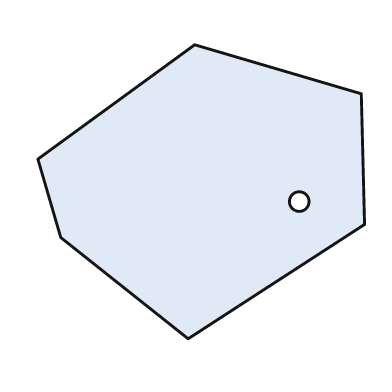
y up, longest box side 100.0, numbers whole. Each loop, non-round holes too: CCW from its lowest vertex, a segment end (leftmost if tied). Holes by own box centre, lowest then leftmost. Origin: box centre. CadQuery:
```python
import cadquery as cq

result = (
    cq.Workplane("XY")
    .moveTo(-4.0, -45.0)
    .lineTo(50.0, -10.0)
    .lineTo(49.0, 30.0)
    .lineTo(-2.0, 45.0)
    .lineTo(-50.0, 10.0)
    .lineTo(-43.0, -14.0)
    .close()
    .moveTo(30.0, -3.0)
    .circle(3.0)
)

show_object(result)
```